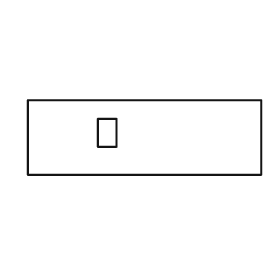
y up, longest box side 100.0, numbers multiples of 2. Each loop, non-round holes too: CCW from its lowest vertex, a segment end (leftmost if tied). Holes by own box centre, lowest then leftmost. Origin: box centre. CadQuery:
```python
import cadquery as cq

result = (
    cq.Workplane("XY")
    .moveTo(-50.0, -16.0)
    .lineTo(50.0, -16.0)
    .lineTo(50.0, 16.0)
    .lineTo(-50.0, 16.0)
    .close()
    .moveTo(-20.0, -4.0)
    .lineTo(-12.0, -4.0)
    .lineTo(-12.0, 8.0)
    .lineTo(-20.0, 8.0)
    .close()
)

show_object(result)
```